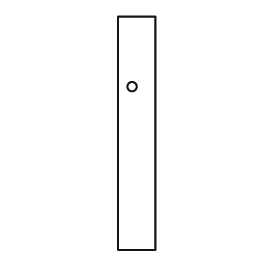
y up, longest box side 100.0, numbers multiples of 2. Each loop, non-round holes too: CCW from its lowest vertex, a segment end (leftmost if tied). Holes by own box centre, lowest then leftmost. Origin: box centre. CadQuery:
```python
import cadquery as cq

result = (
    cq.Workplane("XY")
    .moveTo(-8.0, -50.0)
    .lineTo(8.0, -50.0)
    .lineTo(8.0, 50.0)
    .lineTo(-8.0, 50.0)
    .close()
    .moveTo(-2.0, 20.0)
    .circle(2.0)
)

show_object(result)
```